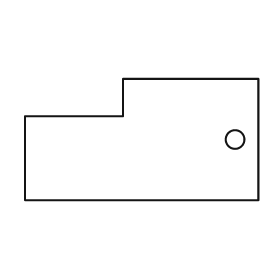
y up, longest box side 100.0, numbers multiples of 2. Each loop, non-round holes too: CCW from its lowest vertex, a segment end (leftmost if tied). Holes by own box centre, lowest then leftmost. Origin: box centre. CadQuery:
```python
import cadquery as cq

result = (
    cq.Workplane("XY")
    .moveTo(-50.0, -26.0)
    .lineTo(50.0, -26.0)
    .lineTo(50.0, 26.0)
    .lineTo(-8.0, 26.0)
    .lineTo(-8.0, 10.0)
    .lineTo(-50.0, 10.0)
    .close()
    .moveTo(40.0, 0.0)
    .circle(4.0)
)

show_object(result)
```